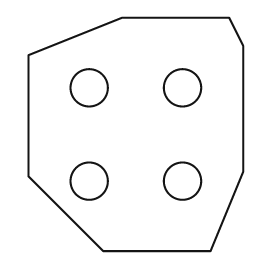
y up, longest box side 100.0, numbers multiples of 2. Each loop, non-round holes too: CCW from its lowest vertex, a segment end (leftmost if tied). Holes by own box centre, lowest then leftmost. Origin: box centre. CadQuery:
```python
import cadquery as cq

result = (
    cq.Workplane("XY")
    .moveTo(-14.0, -50.0)
    .lineTo(32.0, -50.0)
    .lineTo(46.0, -16.0)
    .lineTo(46.0, 38.0)
    .lineTo(40.0, 50.0)
    .lineTo(-6.0, 50.0)
    .lineTo(-46.0, 34.0)
    .lineTo(-46.0, -18.0)
    .close()
    .moveTo(-20.0, -20.0)
    .circle(8.0)
    .moveTo(20.0, -20.0)
    .circle(8.0)
    .moveTo(-20.0, 20.0)
    .circle(8.0)
    .moveTo(20.0, 20.0)
    .circle(8.0)
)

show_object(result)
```